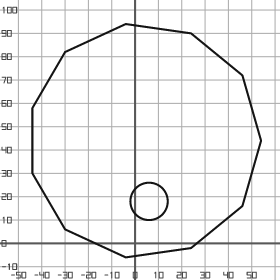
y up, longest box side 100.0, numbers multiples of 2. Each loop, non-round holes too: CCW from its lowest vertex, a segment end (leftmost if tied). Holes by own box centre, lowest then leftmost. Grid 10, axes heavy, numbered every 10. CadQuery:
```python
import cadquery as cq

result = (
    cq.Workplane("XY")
    .moveTo(-4.0, -6.0)
    .lineTo(24.0, -2.0)
    .lineTo(46.0, 16.0)
    .lineTo(54.0, 44.0)
    .lineTo(46.0, 72.0)
    .lineTo(24.0, 90.0)
    .lineTo(-4.0, 94.0)
    .lineTo(-30.0, 82.0)
    .lineTo(-44.0, 58.0)
    .lineTo(-44.0, 30.0)
    .lineTo(-30.0, 6.0)
    .close()
    .moveTo(6.0, 18.0)
    .circle(8.0)
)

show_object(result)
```